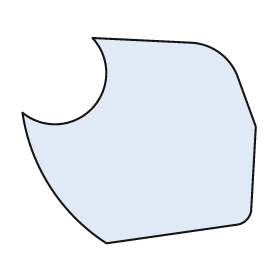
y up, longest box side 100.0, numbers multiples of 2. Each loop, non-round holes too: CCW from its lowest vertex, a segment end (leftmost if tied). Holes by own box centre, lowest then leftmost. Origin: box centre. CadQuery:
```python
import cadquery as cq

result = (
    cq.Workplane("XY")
    .moveTo(-14.0, -44.0)
    .lineTo(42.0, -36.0)
    .threePointArc((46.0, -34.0), (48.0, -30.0))
    .lineTo(50.0, 6.0)
    .lineTo(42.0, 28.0)
    .threePointArc((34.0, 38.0), (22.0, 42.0))
    .lineTo(-20.0, 44.0)
    .threePointArc((-20.0, 14.0), (-50.0, 12.0))
    .threePointArc((-38.0, -20.0), (-14.0, -44.0))
    .close()
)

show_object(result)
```